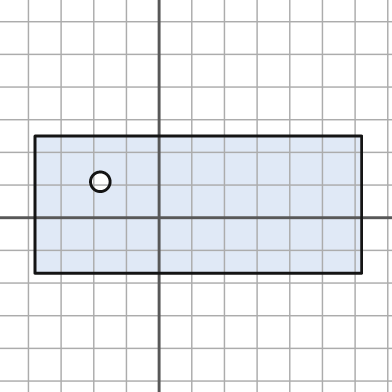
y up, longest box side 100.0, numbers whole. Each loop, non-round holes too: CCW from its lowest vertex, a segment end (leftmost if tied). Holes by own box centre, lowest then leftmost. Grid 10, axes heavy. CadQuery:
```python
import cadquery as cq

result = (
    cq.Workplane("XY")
    .moveTo(-38.0, -17.0)
    .lineTo(62.0, -17.0)
    .lineTo(62.0, 25.0)
    .lineTo(-38.0, 25.0)
    .close()
    .moveTo(-18.0, 11.0)
    .circle(3.0)
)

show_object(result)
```